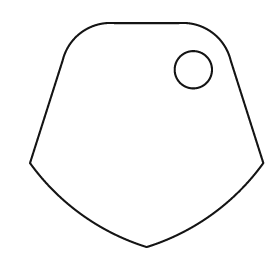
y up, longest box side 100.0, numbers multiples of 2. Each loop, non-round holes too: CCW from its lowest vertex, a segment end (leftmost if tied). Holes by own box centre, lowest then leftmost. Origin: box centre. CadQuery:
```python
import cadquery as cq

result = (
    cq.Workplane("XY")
    .moveTo(0.0, -48.0)
    .threePointArc((28.0, -34.0), (50.0, -12.0))
    .lineTo(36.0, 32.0)
    .threePointArc((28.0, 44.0), (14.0, 48.0))
    .lineTo(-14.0, 48.0)
    .threePointArc((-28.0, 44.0), (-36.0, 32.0))
    .lineTo(-50.0, -12.0)
    .threePointArc((-28.0, -34.0), (0.0, -48.0))
    .close()
    .moveTo(20.0, 28.0)
    .circle(8.0)
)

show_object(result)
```